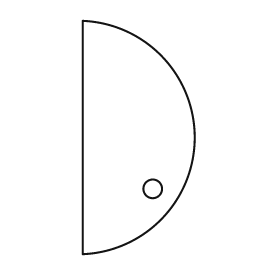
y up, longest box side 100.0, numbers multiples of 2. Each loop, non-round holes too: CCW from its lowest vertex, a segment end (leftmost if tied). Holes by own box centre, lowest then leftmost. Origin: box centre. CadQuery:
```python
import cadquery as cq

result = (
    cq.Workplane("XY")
    .moveTo(-24.0, -50.0)
    .threePointArc((24.0, 0.0), (-24.0, 50.0))
    .close()
    .moveTo(6.0, -22.0)
    .circle(4.0)
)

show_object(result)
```